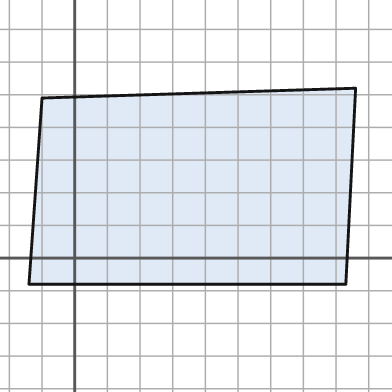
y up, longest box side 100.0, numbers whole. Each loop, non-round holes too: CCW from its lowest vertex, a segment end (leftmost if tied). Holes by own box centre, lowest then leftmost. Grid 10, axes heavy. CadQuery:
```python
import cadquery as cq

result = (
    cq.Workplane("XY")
    .moveTo(-14.0, -8.0)
    .lineTo(83.0, -8.0)
    .lineTo(86.0, 52.0)
    .lineTo(-10.0, 49.0)
    .close()
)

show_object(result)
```